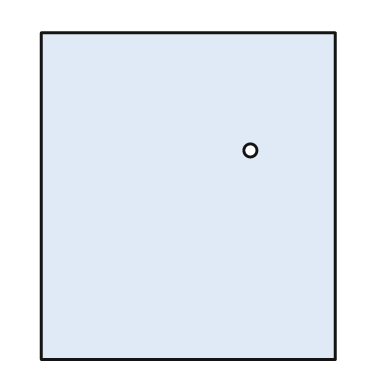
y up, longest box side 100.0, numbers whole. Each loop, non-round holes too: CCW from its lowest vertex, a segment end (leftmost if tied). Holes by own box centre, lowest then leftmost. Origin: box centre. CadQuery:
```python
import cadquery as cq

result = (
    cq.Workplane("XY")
    .moveTo(-45.0, -50.0)
    .lineTo(45.0, -50.0)
    .lineTo(45.0, 50.0)
    .lineTo(-45.0, 50.0)
    .close()
    .moveTo(19.0, 14.0)
    .circle(2.0)
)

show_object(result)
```